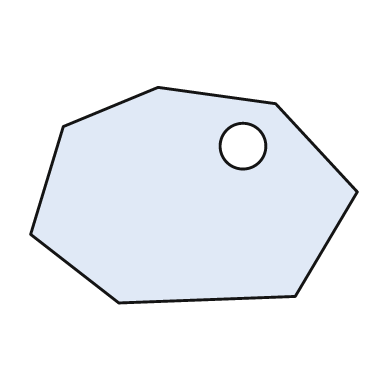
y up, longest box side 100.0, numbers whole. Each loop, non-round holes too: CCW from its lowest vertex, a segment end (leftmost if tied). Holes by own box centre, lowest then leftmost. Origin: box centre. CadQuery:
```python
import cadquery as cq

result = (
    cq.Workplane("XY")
    .moveTo(-23.0, -33.0)
    .lineTo(31.0, -31.0)
    .lineTo(50.0, 1.0)
    .lineTo(25.0, 28.0)
    .lineTo(-11.0, 33.0)
    .lineTo(-40.0, 21.0)
    .lineTo(-50.0, -12.0)
    .close()
    .moveTo(15.0, 15.0)
    .circle(7.0)
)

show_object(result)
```